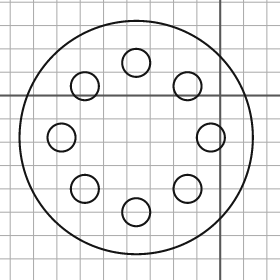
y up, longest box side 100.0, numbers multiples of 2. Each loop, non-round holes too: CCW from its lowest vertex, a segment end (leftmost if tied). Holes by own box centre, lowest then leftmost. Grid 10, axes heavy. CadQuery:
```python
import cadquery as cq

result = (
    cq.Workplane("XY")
    .moveTo(-36.0, -18.0)
    .circle(50.0)
    .moveTo(-36.0, -50.0)
    .circle(6.0)
    .moveTo(-58.0, -40.0)
    .circle(6.0)
    .moveTo(-14.0, -40.0)
    .circle(6.0)
    .moveTo(-68.0, -18.0)
    .circle(6.0)
    .moveTo(-4.0, -18.0)
    .circle(6.0)
    .moveTo(-58.0, 4.0)
    .circle(6.0)
    .moveTo(-14.0, 4.0)
    .circle(6.0)
    .moveTo(-36.0, 14.0)
    .circle(6.0)
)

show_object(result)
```